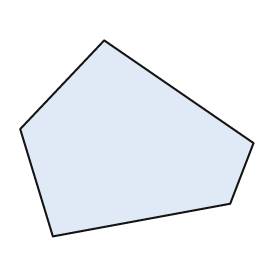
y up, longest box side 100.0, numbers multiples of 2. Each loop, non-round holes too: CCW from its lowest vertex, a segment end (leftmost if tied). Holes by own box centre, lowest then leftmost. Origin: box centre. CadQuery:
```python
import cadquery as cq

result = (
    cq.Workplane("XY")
    .moveTo(-36.0, -42.0)
    .lineTo(40.0, -28.0)
    .lineTo(50.0, -2.0)
    .lineTo(-14.0, 42.0)
    .lineTo(-50.0, 4.0)
    .close()
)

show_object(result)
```